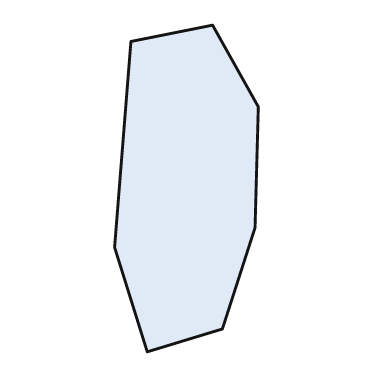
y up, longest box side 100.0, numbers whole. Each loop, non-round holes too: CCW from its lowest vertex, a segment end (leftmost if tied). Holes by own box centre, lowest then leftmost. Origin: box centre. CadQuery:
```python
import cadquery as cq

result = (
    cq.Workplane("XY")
    .moveTo(-12.0, -50.0)
    .lineTo(11.0, -43.0)
    .lineTo(21.0, -12.0)
    .lineTo(22.0, 25.0)
    .lineTo(8.0, 50.0)
    .lineTo(-17.0, 45.0)
    .lineTo(-22.0, -18.0)
    .close()
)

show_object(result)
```